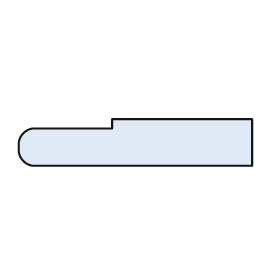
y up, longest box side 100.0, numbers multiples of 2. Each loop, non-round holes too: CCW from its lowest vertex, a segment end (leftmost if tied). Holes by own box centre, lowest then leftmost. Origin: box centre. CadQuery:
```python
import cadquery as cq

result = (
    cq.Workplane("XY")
    .moveTo(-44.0, -10.0)
    .lineTo(50.0, -10.0)
    .lineTo(50.0, 10.0)
    .lineTo(-10.0, 10.0)
    .lineTo(-10.0, 6.0)
    .lineTo(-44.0, 6.0)
    .threePointArc((-48.0, 4.0), (-50.0, 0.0))
    .lineTo(-50.0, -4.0)
    .threePointArc((-48.0, -8.0), (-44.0, -10.0))
    .close()
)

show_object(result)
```